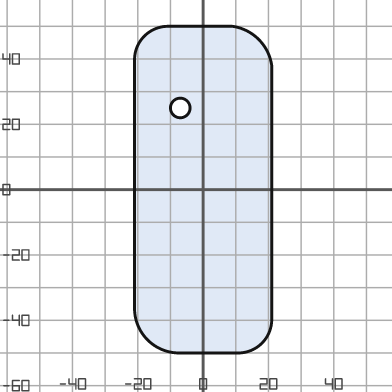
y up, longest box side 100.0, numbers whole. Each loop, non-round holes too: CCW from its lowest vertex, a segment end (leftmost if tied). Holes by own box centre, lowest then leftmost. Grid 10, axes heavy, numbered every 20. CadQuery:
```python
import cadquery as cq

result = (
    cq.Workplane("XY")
    .moveTo(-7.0, -50.0)
    .lineTo(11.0, -50.0)
    .threePointArc((18.0, -47.0), (21.0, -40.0))
    .lineTo(21.0, 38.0)
    .threePointArc((17.0, 46.0), (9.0, 50.0))
    .lineTo(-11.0, 50.0)
    .threePointArc((-18.0, 47.0), (-21.0, 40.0))
    .lineTo(-21.0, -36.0)
    .threePointArc((-17.0, -46.0), (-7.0, -50.0))
    .close()
    .moveTo(-7.0, 25.0)
    .circle(3.0)
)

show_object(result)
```